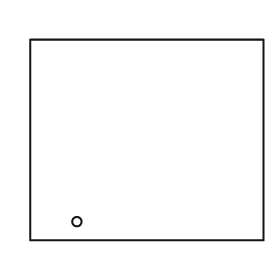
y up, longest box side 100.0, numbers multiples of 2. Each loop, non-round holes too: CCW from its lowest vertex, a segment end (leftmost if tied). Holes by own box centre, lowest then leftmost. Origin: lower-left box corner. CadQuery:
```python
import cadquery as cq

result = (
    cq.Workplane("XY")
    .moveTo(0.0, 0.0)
    .lineTo(100.0, 0.0)
    .lineTo(100.0, 86.0)
    .lineTo(0.0, 86.0)
    .close()
    .moveTo(20.0, 8.0)
    .circle(2.0)
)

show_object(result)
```